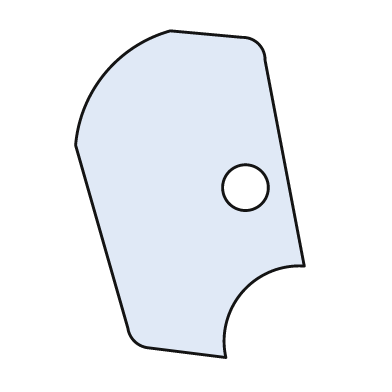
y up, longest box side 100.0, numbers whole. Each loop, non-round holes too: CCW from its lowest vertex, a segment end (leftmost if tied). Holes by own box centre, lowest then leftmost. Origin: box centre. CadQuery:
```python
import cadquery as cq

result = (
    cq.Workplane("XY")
    .moveTo(11.0, -50.0)
    .threePointArc((16.0, -30.0), (35.0, -22.0))
    .lineTo(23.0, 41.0)
    .threePointArc((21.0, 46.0), (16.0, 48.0))
    .lineTo(-6.0, 50.0)
    .threePointArc((-26.0, 37.0), (-35.0, 15.0))
    .lineTo(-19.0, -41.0)
    .threePointArc((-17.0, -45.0), (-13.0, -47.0))
    .close()
    .moveTo(17.0, 2.0)
    .circle(7.0)
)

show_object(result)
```